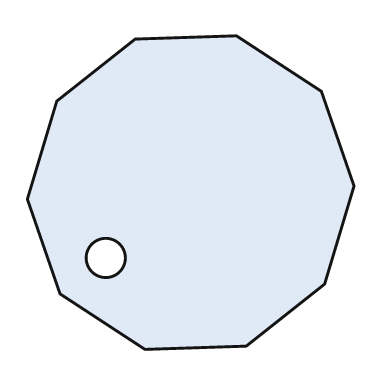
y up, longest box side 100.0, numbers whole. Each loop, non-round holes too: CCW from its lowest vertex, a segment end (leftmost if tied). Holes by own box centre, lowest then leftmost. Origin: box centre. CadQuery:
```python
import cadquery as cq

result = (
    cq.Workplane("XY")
    .moveTo(-14.0, -48.0)
    .lineTo(17.0, -47.0)
    .lineTo(41.0, -28.0)
    .lineTo(50.0, 2.0)
    .lineTo(40.0, 31.0)
    .lineTo(14.0, 48.0)
    .lineTo(-17.0, 47.0)
    .lineTo(-41.0, 28.0)
    .lineTo(-50.0, -2.0)
    .lineTo(-40.0, -31.0)
    .close()
    .moveTo(-26.0, -20.0)
    .circle(6.0)
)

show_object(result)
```